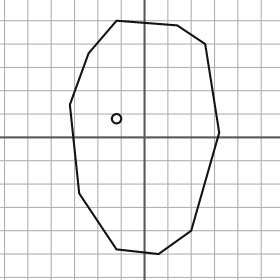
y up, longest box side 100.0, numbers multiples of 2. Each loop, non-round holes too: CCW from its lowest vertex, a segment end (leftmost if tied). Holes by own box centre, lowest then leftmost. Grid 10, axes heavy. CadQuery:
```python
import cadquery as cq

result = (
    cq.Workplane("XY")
    .moveTo(6.0, -50.0)
    .lineTo(20.0, -40.0)
    .lineTo(32.0, 2.0)
    .lineTo(26.0, 40.0)
    .lineTo(14.0, 48.0)
    .lineTo(-12.0, 50.0)
    .lineTo(-24.0, 36.0)
    .lineTo(-32.0, 14.0)
    .lineTo(-28.0, -24.0)
    .lineTo(-12.0, -48.0)
    .close()
    .moveTo(-12.0, 8.0)
    .circle(2.0)
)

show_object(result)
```